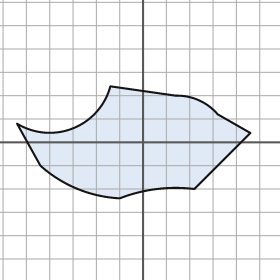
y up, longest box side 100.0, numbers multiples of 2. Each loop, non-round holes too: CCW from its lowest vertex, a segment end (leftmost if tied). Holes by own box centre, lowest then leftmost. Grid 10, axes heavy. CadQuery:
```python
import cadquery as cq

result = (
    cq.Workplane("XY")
    .moveTo(-10.0, -24.0)
    .threePointArc((6.0, -20.0), (22.0, -20.0))
    .lineTo(46.0, 4.0)
    .lineTo(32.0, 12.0)
    .threePointArc((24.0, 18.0), (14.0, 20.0))
    .lineTo(-14.0, 24.0)
    .threePointArc((-30.0, 6.0), (-54.0, 8.0))
    .lineTo(-44.0, -10.0)
    .threePointArc((-28.0, -20.0), (-10.0, -24.0))
    .close()
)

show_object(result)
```